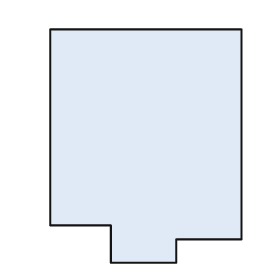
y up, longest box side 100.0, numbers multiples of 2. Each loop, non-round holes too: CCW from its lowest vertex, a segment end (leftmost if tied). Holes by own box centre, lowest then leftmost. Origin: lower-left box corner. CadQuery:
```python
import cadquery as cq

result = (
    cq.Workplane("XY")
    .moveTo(26.0, 0.0)
    .lineTo(54.0, 0.0)
    .lineTo(54.0, 10.0)
    .lineTo(82.0, 10.0)
    .lineTo(82.0, 100.0)
    .lineTo(0.0, 100.0)
    .lineTo(0.0, 16.0)
    .lineTo(26.0, 16.0)
    .close()
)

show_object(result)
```